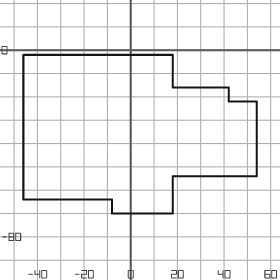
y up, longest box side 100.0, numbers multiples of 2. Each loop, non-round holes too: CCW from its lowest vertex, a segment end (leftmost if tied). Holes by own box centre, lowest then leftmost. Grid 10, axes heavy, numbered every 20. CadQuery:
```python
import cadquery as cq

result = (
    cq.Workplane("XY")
    .moveTo(-8.0, -70.0)
    .lineTo(18.0, -70.0)
    .lineTo(18.0, -54.0)
    .lineTo(54.0, -54.0)
    .lineTo(54.0, -22.0)
    .lineTo(42.0, -22.0)
    .lineTo(42.0, -16.0)
    .lineTo(18.0, -16.0)
    .lineTo(18.0, -2.0)
    .lineTo(-46.0, -2.0)
    .lineTo(-46.0, -64.0)
    .lineTo(-8.0, -64.0)
    .close()
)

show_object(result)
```